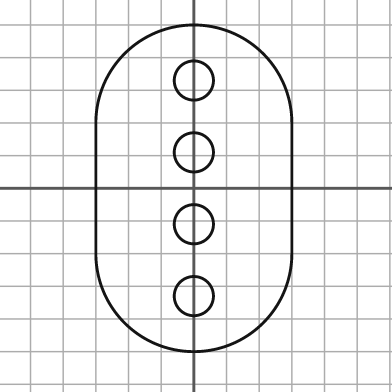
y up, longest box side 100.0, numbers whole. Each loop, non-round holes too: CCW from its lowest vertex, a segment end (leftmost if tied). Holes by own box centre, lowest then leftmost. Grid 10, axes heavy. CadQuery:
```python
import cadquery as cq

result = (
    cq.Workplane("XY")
    .moveTo(-30.0, -20.0)
    .threePointArc((0.0, -50.0), (30.0, -20.0))
    .lineTo(30.0, 20.0)
    .threePointArc((0.0, 50.0), (-30.0, 20.0))
    .close()
    .moveTo(0.0, -33.0)
    .circle(6.0)
    .moveTo(0.0, -11.0)
    .circle(6.0)
    .moveTo(0.0, 11.0)
    .circle(6.0)
    .moveTo(0.0, 33.0)
    .circle(6.0)
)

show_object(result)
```